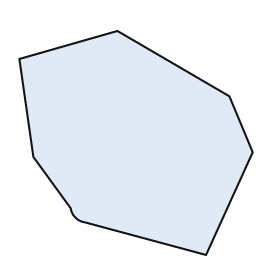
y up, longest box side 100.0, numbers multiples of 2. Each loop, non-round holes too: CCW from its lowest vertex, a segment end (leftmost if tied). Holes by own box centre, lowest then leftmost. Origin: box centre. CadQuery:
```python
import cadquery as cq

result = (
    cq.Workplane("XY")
    .moveTo(30.0, -48.0)
    .lineTo(50.0, -4.0)
    .lineTo(40.0, 20.0)
    .lineTo(-8.0, 48.0)
    .lineTo(-50.0, 36.0)
    .lineTo(-44.0, -6.0)
    .lineTo(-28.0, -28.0)
    .threePointArc((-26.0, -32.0), (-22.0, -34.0))
    .close()
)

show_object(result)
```